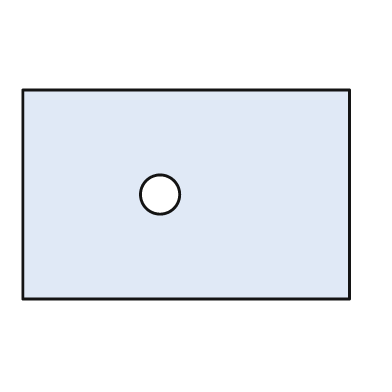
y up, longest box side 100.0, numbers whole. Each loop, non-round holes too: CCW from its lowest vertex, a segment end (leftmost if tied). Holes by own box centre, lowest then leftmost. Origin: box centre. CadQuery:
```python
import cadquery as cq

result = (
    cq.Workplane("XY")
    .moveTo(-50.0, -32.0)
    .lineTo(50.0, -32.0)
    .lineTo(50.0, 32.0)
    .lineTo(-50.0, 32.0)
    .close()
    .moveTo(-8.0, 0.0)
    .circle(6.0)
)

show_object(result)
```